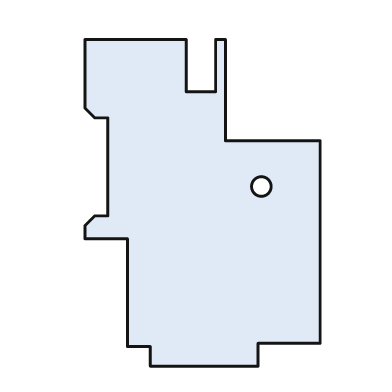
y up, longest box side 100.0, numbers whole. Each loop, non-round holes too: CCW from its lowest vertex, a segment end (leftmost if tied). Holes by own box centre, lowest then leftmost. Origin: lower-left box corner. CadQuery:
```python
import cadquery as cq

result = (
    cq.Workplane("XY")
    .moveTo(20.0, 0.0)
    .lineTo(53.0, 0.0)
    .lineTo(53.0, 7.0)
    .lineTo(72.0, 7.0)
    .lineTo(72.0, 69.0)
    .lineTo(43.0, 69.0)
    .lineTo(43.0, 100.0)
    .lineTo(40.0, 100.0)
    .lineTo(40.0, 84.0)
    .lineTo(31.0, 84.0)
    .lineTo(31.0, 100.0)
    .lineTo(0.0, 100.0)
    .lineTo(0.0, 79.0)
    .lineTo(3.0, 76.0)
    .lineTo(7.0, 76.0)
    .lineTo(7.0, 46.0)
    .lineTo(3.0, 46.0)
    .lineTo(0.0, 43.0)
    .lineTo(0.0, 39.0)
    .lineTo(13.0, 39.0)
    .lineTo(13.0, 6.0)
    .lineTo(20.0, 6.0)
    .close()
    .moveTo(54.0, 55.0)
    .circle(3.0)
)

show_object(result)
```